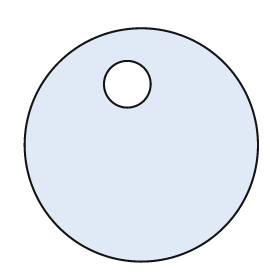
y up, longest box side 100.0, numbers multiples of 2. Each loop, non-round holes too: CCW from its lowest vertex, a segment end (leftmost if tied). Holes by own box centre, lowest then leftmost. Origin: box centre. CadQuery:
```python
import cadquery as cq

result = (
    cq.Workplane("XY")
    .moveTo(0.0, 0.0)
    .circle(50.0)
    .moveTo(-6.0, 26.0)
    .circle(10.0)
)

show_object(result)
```